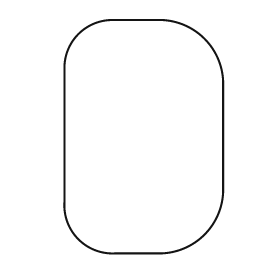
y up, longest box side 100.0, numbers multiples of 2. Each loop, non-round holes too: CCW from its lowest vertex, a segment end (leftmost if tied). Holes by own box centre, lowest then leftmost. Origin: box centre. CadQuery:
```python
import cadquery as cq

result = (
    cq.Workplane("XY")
    .moveTo(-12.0, -50.0)
    .lineTo(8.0, -50.0)
    .threePointArc((26.0, -42.0), (34.0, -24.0))
    .lineTo(34.0, 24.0)
    .threePointArc((26.0, 42.0), (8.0, 50.0))
    .lineTo(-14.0, 50.0)
    .threePointArc((-28.0, 44.0), (-34.0, 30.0))
    .lineTo(-34.0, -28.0)
    .threePointArc((-28.0, -44.0), (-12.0, -50.0))
    .close()
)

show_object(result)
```